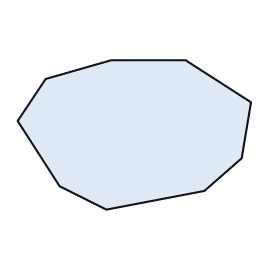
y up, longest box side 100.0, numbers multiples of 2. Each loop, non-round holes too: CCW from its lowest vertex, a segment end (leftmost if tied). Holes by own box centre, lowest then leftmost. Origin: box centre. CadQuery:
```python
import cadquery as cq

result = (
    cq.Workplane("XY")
    .moveTo(-12.0, -32.0)
    .lineTo(30.0, -24.0)
    .lineTo(46.0, -10.0)
    .lineTo(50.0, 14.0)
    .lineTo(22.0, 32.0)
    .lineTo(-10.0, 32.0)
    .lineTo(-38.0, 24.0)
    .lineTo(-50.0, 6.0)
    .lineTo(-32.0, -22.0)
    .close()
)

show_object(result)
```